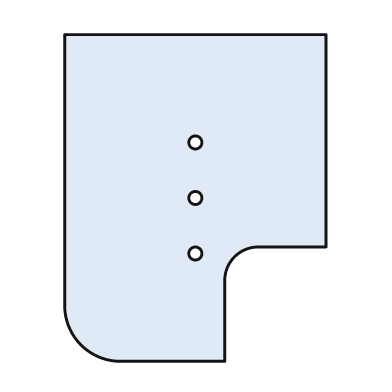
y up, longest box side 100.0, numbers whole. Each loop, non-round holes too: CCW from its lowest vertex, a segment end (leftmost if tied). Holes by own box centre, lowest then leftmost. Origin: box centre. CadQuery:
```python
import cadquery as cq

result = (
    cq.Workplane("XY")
    .moveTo(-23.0, -50.0)
    .lineTo(9.0, -50.0)
    .lineTo(9.0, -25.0)
    .threePointArc((12.0, -18.0), (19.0, -15.0))
    .lineTo(40.0, -15.0)
    .lineTo(40.0, 50.0)
    .lineTo(-40.0, 50.0)
    .lineTo(-40.0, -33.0)
    .threePointArc((-35.0, -45.0), (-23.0, -50.0))
    .close()
    .moveTo(0.0, -17.0)
    .circle(2.0)
    .moveTo(0.0, 0.0)
    .circle(2.0)
    .moveTo(0.0, 17.0)
    .circle(2.0)
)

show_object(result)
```